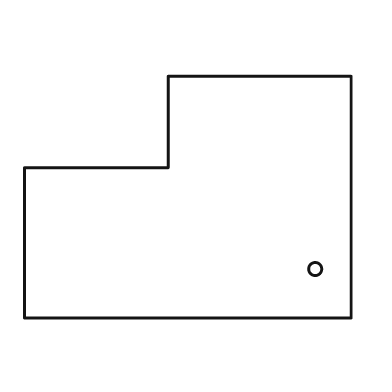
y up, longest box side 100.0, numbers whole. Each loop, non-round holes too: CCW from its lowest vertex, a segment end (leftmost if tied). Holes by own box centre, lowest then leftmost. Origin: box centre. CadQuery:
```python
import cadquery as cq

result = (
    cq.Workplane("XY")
    .moveTo(-50.0, -37.0)
    .lineTo(50.0, -37.0)
    .lineTo(50.0, 37.0)
    .lineTo(-6.0, 37.0)
    .lineTo(-6.0, 9.0)
    .lineTo(-50.0, 9.0)
    .close()
    .moveTo(39.0, -22.0)
    .circle(2.0)
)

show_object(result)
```